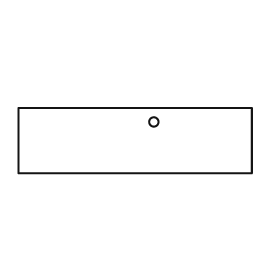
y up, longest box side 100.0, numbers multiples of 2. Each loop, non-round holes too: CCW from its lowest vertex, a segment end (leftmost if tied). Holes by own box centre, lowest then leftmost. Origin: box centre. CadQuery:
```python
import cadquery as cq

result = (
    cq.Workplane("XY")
    .moveTo(-50.0, -14.0)
    .lineTo(50.0, -14.0)
    .lineTo(50.0, 14.0)
    .lineTo(-50.0, 14.0)
    .close()
    .moveTo(8.0, 8.0)
    .circle(2.0)
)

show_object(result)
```